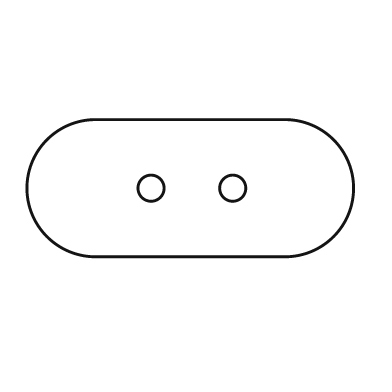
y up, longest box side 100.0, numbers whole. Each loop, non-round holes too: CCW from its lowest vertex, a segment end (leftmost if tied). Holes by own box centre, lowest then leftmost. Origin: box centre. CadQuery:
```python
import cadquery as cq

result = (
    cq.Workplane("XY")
    .moveTo(-29.0, -21.0)
    .lineTo(29.0, -21.0)
    .threePointArc((50.0, 0.0), (29.0, 21.0))
    .lineTo(-29.0, 21.0)
    .threePointArc((-50.0, 0.0), (-29.0, -21.0))
    .close()
    .moveTo(-12.0, 0.0)
    .circle(4.0)
    .moveTo(13.0, 0.0)
    .circle(4.0)
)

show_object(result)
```